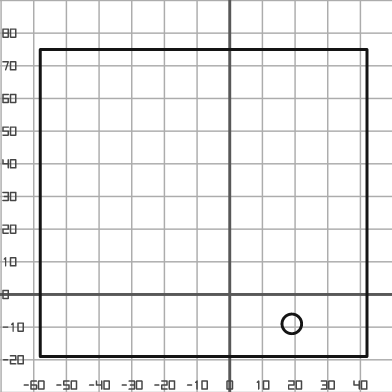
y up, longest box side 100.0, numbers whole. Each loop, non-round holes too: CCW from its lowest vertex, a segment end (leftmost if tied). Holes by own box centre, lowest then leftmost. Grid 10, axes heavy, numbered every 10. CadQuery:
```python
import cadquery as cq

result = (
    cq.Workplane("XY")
    .moveTo(-58.0, -19.0)
    .lineTo(42.0, -19.0)
    .lineTo(42.0, 75.0)
    .lineTo(-58.0, 75.0)
    .close()
    .moveTo(19.0, -9.0)
    .circle(3.0)
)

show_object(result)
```